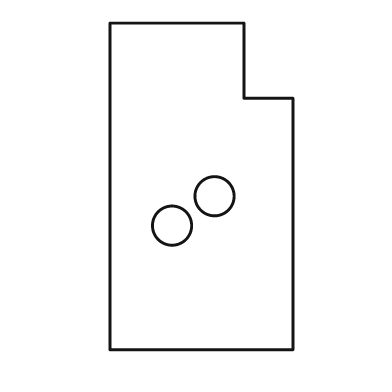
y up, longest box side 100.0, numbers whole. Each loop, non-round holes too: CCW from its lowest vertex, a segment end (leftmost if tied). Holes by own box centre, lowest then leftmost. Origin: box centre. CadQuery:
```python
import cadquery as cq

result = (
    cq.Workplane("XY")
    .moveTo(-28.0, -50.0)
    .lineTo(28.0, -50.0)
    .lineTo(28.0, 27.0)
    .lineTo(13.0, 27.0)
    .lineTo(13.0, 50.0)
    .lineTo(-28.0, 50.0)
    .close()
    .moveTo(-9.0, -12.0)
    .circle(6.0)
    .moveTo(4.0, -3.0)
    .circle(6.0)
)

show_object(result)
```